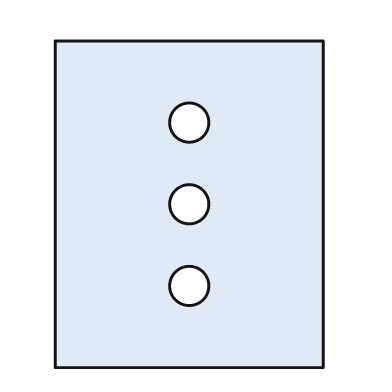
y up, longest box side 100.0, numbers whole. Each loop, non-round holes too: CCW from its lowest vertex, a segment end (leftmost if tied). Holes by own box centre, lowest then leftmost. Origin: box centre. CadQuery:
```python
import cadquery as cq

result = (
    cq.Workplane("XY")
    .moveTo(-41.0, -50.0)
    .lineTo(41.0, -50.0)
    .lineTo(41.0, 50.0)
    .lineTo(-41.0, 50.0)
    .close()
    .moveTo(0.0, -25.0)
    .circle(6.0)
    .moveTo(0.0, 0.0)
    .circle(6.0)
    .moveTo(0.0, 25.0)
    .circle(6.0)
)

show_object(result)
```